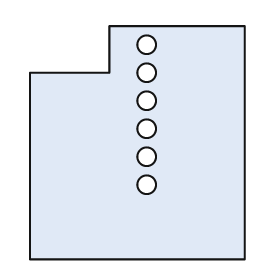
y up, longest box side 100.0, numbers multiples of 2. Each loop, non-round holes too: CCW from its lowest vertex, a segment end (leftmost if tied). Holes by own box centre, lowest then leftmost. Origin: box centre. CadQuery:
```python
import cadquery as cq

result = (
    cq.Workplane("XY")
    .moveTo(-46.0, -50.0)
    .lineTo(46.0, -50.0)
    .lineTo(46.0, 50.0)
    .lineTo(-12.0, 50.0)
    .lineTo(-12.0, 30.0)
    .lineTo(-46.0, 30.0)
    .close()
    .moveTo(4.0, -18.0)
    .circle(4.0)
    .moveTo(4.0, -6.0)
    .circle(4.0)
    .moveTo(4.0, 6.0)
    .circle(4.0)
    .moveTo(4.0, 18.0)
    .circle(4.0)
    .moveTo(4.0, 30.0)
    .circle(4.0)
    .moveTo(4.0, 42.0)
    .circle(4.0)
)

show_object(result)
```